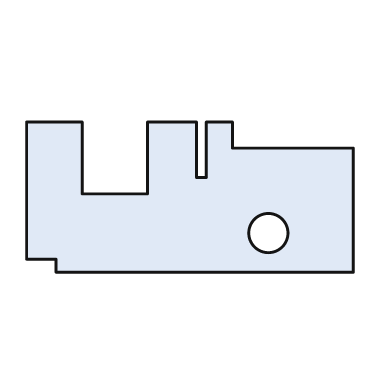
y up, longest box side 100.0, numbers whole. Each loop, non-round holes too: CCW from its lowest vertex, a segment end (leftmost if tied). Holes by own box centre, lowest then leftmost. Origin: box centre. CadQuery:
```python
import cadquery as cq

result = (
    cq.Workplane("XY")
    .moveTo(-41.0, -23.0)
    .lineTo(50.0, -23.0)
    .lineTo(50.0, 15.0)
    .lineTo(13.0, 15.0)
    .lineTo(13.0, 23.0)
    .lineTo(5.0, 23.0)
    .lineTo(5.0, 6.0)
    .lineTo(2.0, 6.0)
    .lineTo(2.0, 23.0)
    .lineTo(-13.0, 23.0)
    .lineTo(-13.0, 1.0)
    .lineTo(-33.0, 1.0)
    .lineTo(-33.0, 23.0)
    .lineTo(-50.0, 23.0)
    .lineTo(-50.0, -19.0)
    .lineTo(-41.0, -19.0)
    .close()
    .moveTo(24.0, -11.0)
    .circle(6.0)
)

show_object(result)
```